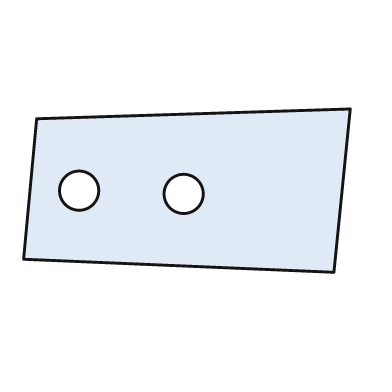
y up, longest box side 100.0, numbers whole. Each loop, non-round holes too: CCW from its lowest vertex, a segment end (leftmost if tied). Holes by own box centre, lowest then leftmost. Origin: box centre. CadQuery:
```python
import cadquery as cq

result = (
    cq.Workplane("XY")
    .moveTo(45.0, -25.0)
    .lineTo(50.0, 25.0)
    .lineTo(-46.0, 22.0)
    .lineTo(-50.0, -21.0)
    .close()
    .moveTo(-1.0, -1.0)
    .circle(6.0)
    .moveTo(-33.0, 0.0)
    .circle(6.0)
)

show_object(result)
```